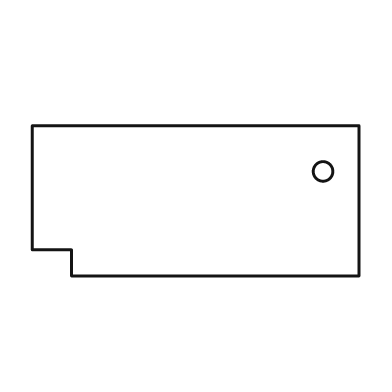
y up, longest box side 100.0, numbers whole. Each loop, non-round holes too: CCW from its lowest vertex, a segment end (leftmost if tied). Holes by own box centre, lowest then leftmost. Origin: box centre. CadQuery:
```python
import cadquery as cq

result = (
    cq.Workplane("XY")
    .moveTo(-38.0, -23.0)
    .lineTo(50.0, -23.0)
    .lineTo(50.0, 23.0)
    .lineTo(-50.0, 23.0)
    .lineTo(-50.0, -15.0)
    .lineTo(-38.0, -15.0)
    .close()
    .moveTo(39.0, 9.0)
    .circle(3.0)
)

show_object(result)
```